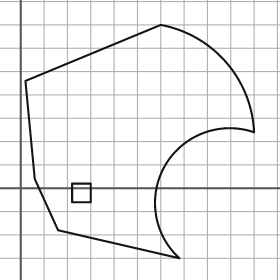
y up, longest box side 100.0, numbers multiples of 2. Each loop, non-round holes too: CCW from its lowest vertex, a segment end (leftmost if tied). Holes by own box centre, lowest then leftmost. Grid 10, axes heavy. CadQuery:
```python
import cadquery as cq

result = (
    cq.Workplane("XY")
    .moveTo(68.0, -30.0)
    .threePointArc((62.0, 10.0), (100.0, 24.0))
    .threePointArc((88.0, 54.0), (60.0, 70.0))
    .lineTo(2.0, 46.0)
    .lineTo(6.0, 4.0)
    .lineTo(16.0, -18.0)
    .close()
    .moveTo(22.0, -6.0)
    .lineTo(30.0, -6.0)
    .lineTo(30.0, 2.0)
    .lineTo(22.0, 2.0)
    .close()
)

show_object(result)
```